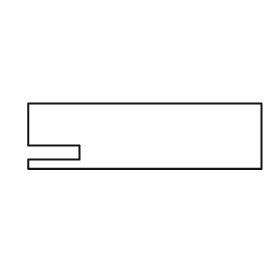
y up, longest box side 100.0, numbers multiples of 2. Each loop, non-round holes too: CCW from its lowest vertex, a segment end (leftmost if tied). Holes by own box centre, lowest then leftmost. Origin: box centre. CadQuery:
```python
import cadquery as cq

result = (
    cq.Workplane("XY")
    .moveTo(-50.0, -14.0)
    .lineTo(50.0, -14.0)
    .lineTo(50.0, 14.0)
    .lineTo(-50.0, 14.0)
    .lineTo(-50.0, -4.0)
    .lineTo(-28.0, -4.0)
    .lineTo(-28.0, -10.0)
    .lineTo(-50.0, -10.0)
    .close()
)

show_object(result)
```